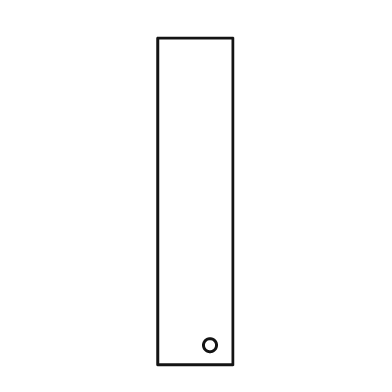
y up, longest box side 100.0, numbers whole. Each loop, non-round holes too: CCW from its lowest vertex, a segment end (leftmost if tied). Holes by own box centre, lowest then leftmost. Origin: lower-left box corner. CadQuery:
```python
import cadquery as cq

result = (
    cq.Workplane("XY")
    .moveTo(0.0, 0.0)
    .lineTo(23.0, 0.0)
    .lineTo(23.0, 100.0)
    .lineTo(0.0, 100.0)
    .close()
    .moveTo(16.0, 6.0)
    .circle(2.0)
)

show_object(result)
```